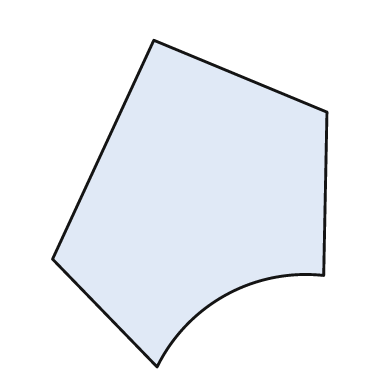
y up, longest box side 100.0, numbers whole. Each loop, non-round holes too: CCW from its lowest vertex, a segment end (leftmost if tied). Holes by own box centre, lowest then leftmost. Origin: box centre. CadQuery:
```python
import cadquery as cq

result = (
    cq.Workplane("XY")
    .moveTo(-10.0, -50.0)
    .threePointArc((11.0, -28.0), (41.0, -22.0))
    .lineTo(42.0, 28.0)
    .lineTo(-11.0, 50.0)
    .lineTo(-42.0, -17.0)
    .close()
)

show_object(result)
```